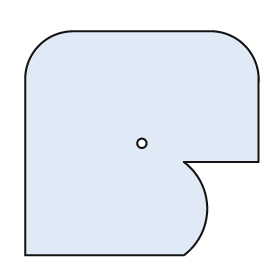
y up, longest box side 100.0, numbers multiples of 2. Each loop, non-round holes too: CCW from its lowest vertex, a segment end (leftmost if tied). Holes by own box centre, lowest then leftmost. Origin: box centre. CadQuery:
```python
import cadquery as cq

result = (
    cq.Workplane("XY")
    .moveTo(-50.0, -48.0)
    .lineTo(18.0, -48.0)
    .threePointArc((28.0, -28.0), (18.0, -8.0))
    .lineTo(50.0, -8.0)
    .lineTo(50.0, 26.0)
    .threePointArc((44.0, 42.0), (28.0, 48.0))
    .lineTo(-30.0, 48.0)
    .threePointArc((-44.0, 42.0), (-50.0, 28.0))
    .close()
    .moveTo(0.0, 0.0)
    .circle(2.0)
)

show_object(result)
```